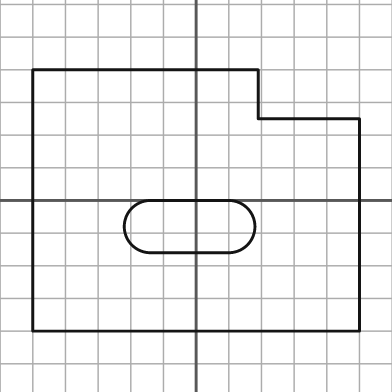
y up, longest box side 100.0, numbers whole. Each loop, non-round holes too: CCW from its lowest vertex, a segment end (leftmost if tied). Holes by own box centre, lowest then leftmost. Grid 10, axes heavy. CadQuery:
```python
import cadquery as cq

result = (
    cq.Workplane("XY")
    .moveTo(-50.0, -40.0)
    .lineTo(50.0, -40.0)
    .lineTo(50.0, 25.0)
    .lineTo(19.0, 25.0)
    .lineTo(19.0, 40.0)
    .lineTo(-50.0, 40.0)
    .close()
    .moveTo(-14.0, -16.0)
    .lineTo(10.0, -16.0)
    .threePointArc((18.0, -8.0), (10.0, 0.0))
    .lineTo(-14.0, 0.0)
    .threePointArc((-22.0, -8.0), (-14.0, -16.0))
    .close()
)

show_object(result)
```